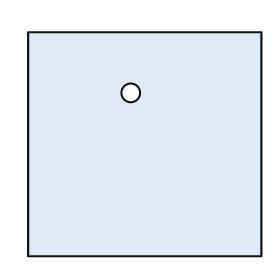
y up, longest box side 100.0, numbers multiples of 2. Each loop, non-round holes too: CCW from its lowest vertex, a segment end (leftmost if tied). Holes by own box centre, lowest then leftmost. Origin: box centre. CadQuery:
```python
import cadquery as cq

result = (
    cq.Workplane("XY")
    .moveTo(-50.0, -48.0)
    .lineTo(50.0, -48.0)
    .lineTo(50.0, 48.0)
    .lineTo(-50.0, 48.0)
    .close()
    .moveTo(-6.0, 22.0)
    .circle(4.0)
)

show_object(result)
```